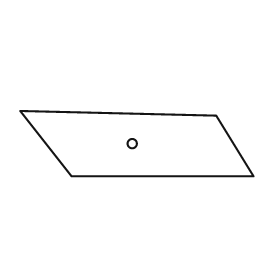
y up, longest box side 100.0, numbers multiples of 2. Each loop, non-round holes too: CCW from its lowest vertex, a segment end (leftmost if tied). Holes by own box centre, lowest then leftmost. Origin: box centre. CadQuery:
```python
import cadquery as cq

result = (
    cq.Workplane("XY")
    .moveTo(-28.0, -14.0)
    .lineTo(50.0, -14.0)
    .lineTo(34.0, 12.0)
    .lineTo(-50.0, 14.0)
    .close()
    .moveTo(-2.0, 0.0)
    .circle(2.0)
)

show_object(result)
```